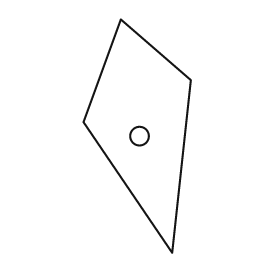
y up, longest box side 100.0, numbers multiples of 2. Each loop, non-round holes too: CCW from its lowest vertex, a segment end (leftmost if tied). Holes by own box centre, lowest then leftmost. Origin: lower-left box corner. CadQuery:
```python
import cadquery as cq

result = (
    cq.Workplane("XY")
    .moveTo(38.0, 0.0)
    .lineTo(46.0, 74.0)
    .lineTo(16.0, 100.0)
    .lineTo(0.0, 56.0)
    .close()
    .moveTo(24.0, 50.0)
    .circle(4.0)
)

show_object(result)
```